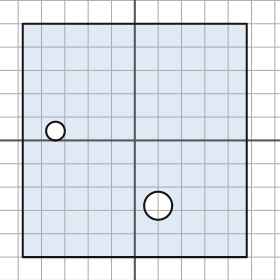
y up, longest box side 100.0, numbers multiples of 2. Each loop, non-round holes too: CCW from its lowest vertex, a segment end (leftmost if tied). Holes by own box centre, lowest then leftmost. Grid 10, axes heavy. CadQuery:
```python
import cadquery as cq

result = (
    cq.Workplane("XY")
    .moveTo(-48.0, -50.0)
    .lineTo(48.0, -50.0)
    .lineTo(48.0, 50.0)
    .lineTo(-48.0, 50.0)
    .close()
    .moveTo(10.0, -28.0)
    .circle(6.0)
    .moveTo(-34.0, 4.0)
    .circle(4.0)
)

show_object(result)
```